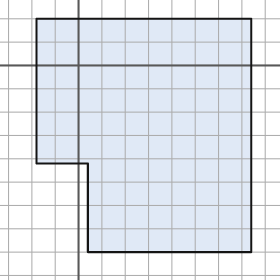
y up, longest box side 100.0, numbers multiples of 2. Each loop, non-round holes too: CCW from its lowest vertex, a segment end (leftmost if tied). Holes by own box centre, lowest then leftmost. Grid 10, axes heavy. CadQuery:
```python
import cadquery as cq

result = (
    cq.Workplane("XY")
    .moveTo(4.0, -80.0)
    .lineTo(74.0, -80.0)
    .lineTo(74.0, 20.0)
    .lineTo(-18.0, 20.0)
    .lineTo(-18.0, -42.0)
    .lineTo(4.0, -42.0)
    .close()
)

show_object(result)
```